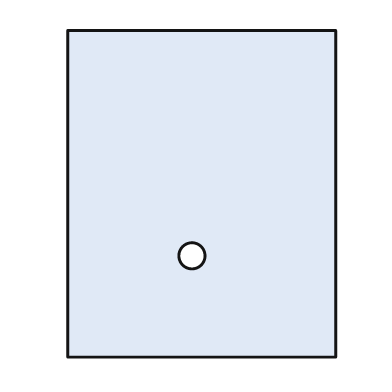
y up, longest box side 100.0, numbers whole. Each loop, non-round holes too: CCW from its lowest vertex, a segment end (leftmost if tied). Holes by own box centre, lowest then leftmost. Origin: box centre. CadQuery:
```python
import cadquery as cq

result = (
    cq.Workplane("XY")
    .moveTo(-41.0, -50.0)
    .lineTo(41.0, -50.0)
    .lineTo(41.0, 50.0)
    .lineTo(-41.0, 50.0)
    .close()
    .moveTo(-3.0, -19.0)
    .circle(4.0)
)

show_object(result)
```